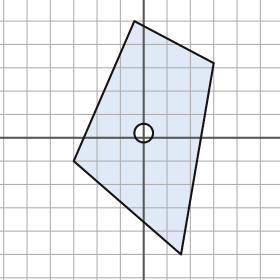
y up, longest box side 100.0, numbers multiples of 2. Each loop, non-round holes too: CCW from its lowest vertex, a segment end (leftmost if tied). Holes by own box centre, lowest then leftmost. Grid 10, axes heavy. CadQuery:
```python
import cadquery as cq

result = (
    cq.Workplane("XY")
    .moveTo(16.0, -50.0)
    .lineTo(30.0, 32.0)
    .lineTo(-4.0, 50.0)
    .lineTo(-30.0, -10.0)
    .close()
    .moveTo(0.0, 2.0)
    .circle(4.0)
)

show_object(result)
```